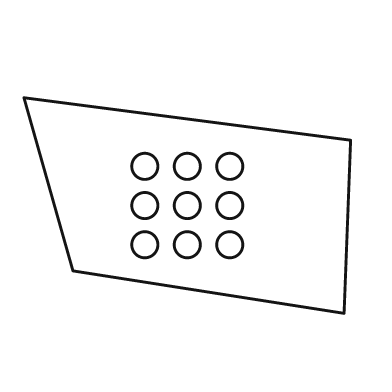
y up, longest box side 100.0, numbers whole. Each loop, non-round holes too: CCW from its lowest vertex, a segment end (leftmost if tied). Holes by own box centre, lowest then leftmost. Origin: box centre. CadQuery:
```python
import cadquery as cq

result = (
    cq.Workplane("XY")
    .moveTo(48.0, -33.0)
    .lineTo(50.0, 20.0)
    .lineTo(-50.0, 33.0)
    .lineTo(-35.0, -20.0)
    .close()
    .moveTo(-13.0, -12.0)
    .circle(4.0)
    .moveTo(0.0, -12.0)
    .circle(4.0)
    .moveTo(13.0, -12.0)
    .circle(4.0)
    .moveTo(-13.0, 0.0)
    .circle(4.0)
    .moveTo(0.0, 0.0)
    .circle(4.0)
    .moveTo(13.0, 0.0)
    .circle(4.0)
    .moveTo(-13.0, 12.0)
    .circle(4.0)
    .moveTo(0.0, 12.0)
    .circle(4.0)
    .moveTo(13.0, 12.0)
    .circle(4.0)
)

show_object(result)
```